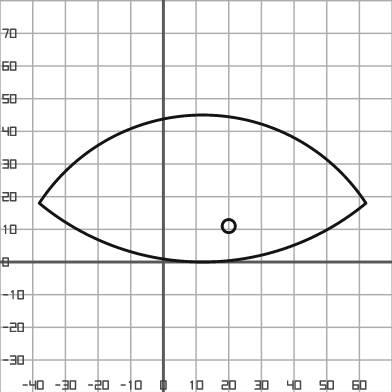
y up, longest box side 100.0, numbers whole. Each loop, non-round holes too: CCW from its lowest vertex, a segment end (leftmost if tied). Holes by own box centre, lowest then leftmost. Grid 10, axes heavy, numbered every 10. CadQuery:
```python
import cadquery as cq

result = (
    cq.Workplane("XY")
    .moveTo(-38.0, 18.0)
    .threePointArc((12.0, 0.0), (62.0, 18.0))
    .threePointArc((12.0, 45.0), (-38.0, 18.0))
    .close()
    .moveTo(20.0, 11.0)
    .circle(2.0)
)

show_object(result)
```